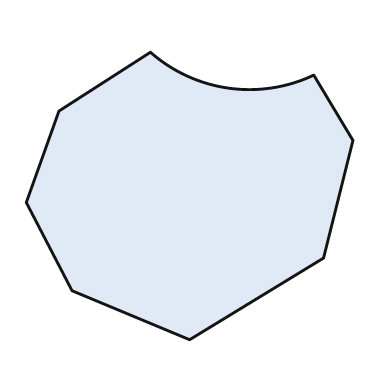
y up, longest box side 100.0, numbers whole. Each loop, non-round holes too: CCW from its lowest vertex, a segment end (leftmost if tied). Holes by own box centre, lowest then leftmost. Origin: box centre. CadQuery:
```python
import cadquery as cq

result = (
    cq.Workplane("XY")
    .moveTo(0.0, -44.0)
    .lineTo(41.0, -19.0)
    .lineTo(50.0, 17.0)
    .lineTo(38.0, 37.0)
    .threePointArc((12.0, 33.0), (-12.0, 44.0))
    .lineTo(-40.0, 26.0)
    .lineTo(-50.0, -2.0)
    .lineTo(-36.0, -29.0)
    .close()
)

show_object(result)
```